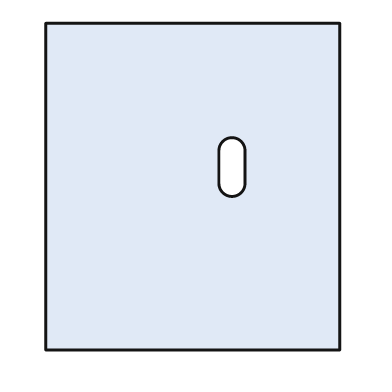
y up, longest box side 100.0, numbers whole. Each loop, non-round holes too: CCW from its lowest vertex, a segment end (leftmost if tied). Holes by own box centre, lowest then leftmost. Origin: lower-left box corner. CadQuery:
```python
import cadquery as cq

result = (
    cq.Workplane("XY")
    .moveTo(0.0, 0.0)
    .lineTo(90.0, 0.0)
    .lineTo(90.0, 100.0)
    .lineTo(0.0, 100.0)
    .close()
    .moveTo(53.0, 51.0)
    .threePointArc((57.0, 47.0), (61.0, 51.0))
    .lineTo(61.0, 61.0)
    .threePointArc((57.0, 65.0), (53.0, 61.0))
    .close()
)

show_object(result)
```